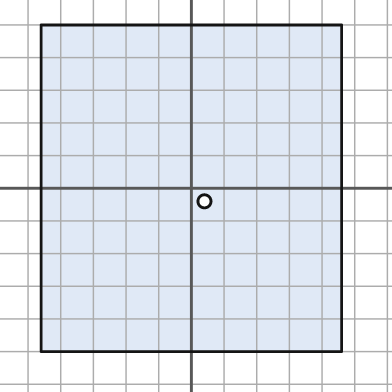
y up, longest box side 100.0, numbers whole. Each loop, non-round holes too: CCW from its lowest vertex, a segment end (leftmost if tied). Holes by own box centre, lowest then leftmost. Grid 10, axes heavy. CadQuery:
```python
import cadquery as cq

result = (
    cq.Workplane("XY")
    .moveTo(-46.0, -50.0)
    .lineTo(46.0, -50.0)
    .lineTo(46.0, 50.0)
    .lineTo(-46.0, 50.0)
    .close()
    .moveTo(4.0, -4.0)
    .circle(2.0)
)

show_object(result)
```